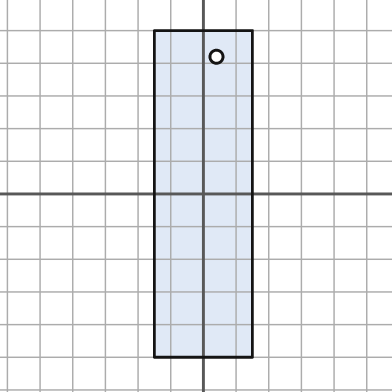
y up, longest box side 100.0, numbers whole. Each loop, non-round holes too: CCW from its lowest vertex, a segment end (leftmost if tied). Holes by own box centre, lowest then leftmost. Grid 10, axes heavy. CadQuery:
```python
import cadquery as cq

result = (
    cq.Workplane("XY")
    .moveTo(-15.0, -50.0)
    .lineTo(15.0, -50.0)
    .lineTo(15.0, 50.0)
    .lineTo(-15.0, 50.0)
    .close()
    .moveTo(4.0, 42.0)
    .circle(2.0)
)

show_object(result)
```